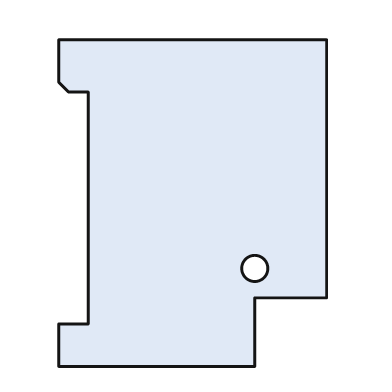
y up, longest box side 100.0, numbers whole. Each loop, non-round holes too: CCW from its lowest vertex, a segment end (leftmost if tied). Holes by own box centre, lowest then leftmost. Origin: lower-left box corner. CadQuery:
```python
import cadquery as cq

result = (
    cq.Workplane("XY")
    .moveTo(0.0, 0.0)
    .lineTo(60.0, 0.0)
    .lineTo(60.0, 21.0)
    .lineTo(82.0, 21.0)
    .lineTo(82.0, 100.0)
    .lineTo(0.0, 100.0)
    .lineTo(0.0, 87.0)
    .lineTo(3.0, 84.0)
    .lineTo(9.0, 84.0)
    .lineTo(9.0, 13.0)
    .lineTo(0.0, 13.0)
    .close()
    .moveTo(60.0, 30.0)
    .circle(4.0)
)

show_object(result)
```